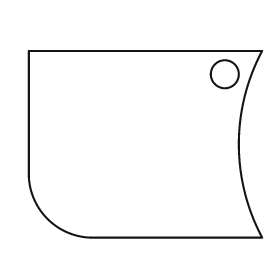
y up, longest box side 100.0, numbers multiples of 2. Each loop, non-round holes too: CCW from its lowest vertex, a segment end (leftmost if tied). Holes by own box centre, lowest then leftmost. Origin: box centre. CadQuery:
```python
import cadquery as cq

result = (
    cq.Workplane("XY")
    .moveTo(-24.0, -40.0)
    .lineTo(50.0, -40.0)
    .threePointArc((40.0, 0.0), (50.0, 40.0))
    .lineTo(-50.0, 40.0)
    .lineTo(-50.0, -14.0)
    .threePointArc((-42.0, -32.0), (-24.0, -40.0))
    .close()
    .moveTo(34.0, 30.0)
    .circle(6.0)
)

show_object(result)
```